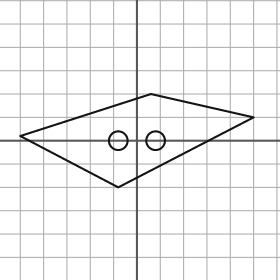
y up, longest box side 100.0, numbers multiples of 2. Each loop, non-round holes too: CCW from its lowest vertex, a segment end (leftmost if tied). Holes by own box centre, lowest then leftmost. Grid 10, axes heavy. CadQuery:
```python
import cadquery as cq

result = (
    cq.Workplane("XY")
    .moveTo(-8.0, -20.0)
    .lineTo(50.0, 10.0)
    .lineTo(6.0, 20.0)
    .lineTo(-50.0, 2.0)
    .close()
    .moveTo(-8.0, 0.0)
    .circle(4.0)
    .moveTo(8.0, 0.0)
    .circle(4.0)
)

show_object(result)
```